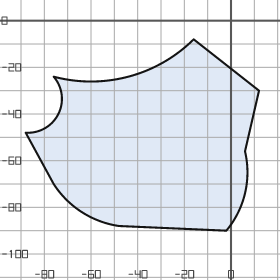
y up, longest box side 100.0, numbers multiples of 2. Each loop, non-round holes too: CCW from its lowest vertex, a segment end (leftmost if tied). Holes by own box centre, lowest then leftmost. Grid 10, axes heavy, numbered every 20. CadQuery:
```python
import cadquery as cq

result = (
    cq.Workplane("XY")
    .moveTo(-2.0, -90.0)
    .threePointArc((6.0, -74.0), (6.0, -56.0))
    .lineTo(12.0, -30.0)
    .lineTo(-16.0, -8.0)
    .threePointArc((-44.0, -24.0), (-76.0, -24.0))
    .threePointArc((-74.0, -40.0), (-88.0, -48.0))
    .lineTo(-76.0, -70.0)
    .threePointArc((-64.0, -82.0), (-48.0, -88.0))
    .close()
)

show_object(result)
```